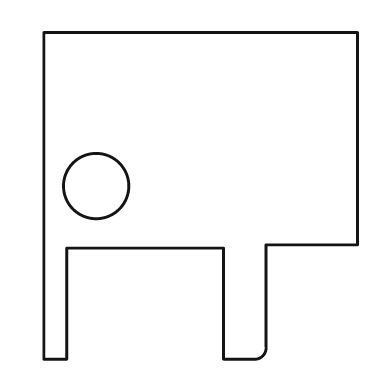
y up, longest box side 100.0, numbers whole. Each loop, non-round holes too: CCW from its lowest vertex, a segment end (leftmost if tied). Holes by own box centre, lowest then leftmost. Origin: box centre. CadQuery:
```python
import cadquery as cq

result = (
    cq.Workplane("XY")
    .moveTo(-48.0, -50.0)
    .lineTo(-41.0, -50.0)
    .lineTo(-41.0, -16.0)
    .lineTo(7.0, -16.0)
    .lineTo(7.0, -50.0)
    .lineTo(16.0, -50.0)
    .threePointArc((19.0, -49.0), (20.0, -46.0))
    .lineTo(20.0, -15.0)
    .lineTo(48.0, -15.0)
    .lineTo(48.0, 50.0)
    .lineTo(-48.0, 50.0)
    .close()
    .moveTo(-32.0, 3.0)
    .circle(10.0)
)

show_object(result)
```